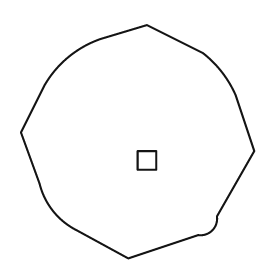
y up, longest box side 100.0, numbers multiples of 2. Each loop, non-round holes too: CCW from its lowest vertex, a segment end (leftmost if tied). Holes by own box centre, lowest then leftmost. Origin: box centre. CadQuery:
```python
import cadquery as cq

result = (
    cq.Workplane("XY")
    .moveTo(-4.0, -50.0)
    .lineTo(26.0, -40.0)
    .threePointArc((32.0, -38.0), (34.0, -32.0))
    .lineTo(50.0, -4.0)
    .lineTo(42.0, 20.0)
    .threePointArc((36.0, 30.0), (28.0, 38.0))
    .lineTo(4.0, 50.0)
    .lineTo(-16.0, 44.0)
    .threePointArc((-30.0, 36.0), (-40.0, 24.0))
    .lineTo(-50.0, 4.0)
    .lineTo(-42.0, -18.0)
    .threePointArc((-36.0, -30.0), (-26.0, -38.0))
    .close()
    .moveTo(0.0, -12.0)
    .lineTo(8.0, -12.0)
    .lineTo(8.0, -4.0)
    .lineTo(0.0, -4.0)
    .close()
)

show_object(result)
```